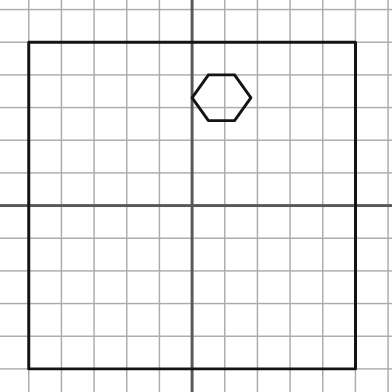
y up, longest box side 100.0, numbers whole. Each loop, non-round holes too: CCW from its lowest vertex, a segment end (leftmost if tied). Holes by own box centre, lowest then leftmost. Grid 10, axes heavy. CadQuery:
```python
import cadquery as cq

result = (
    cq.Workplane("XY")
    .moveTo(-50.0, -50.0)
    .lineTo(50.0, -50.0)
    .lineTo(50.0, 50.0)
    .lineTo(-50.0, 50.0)
    .close()
    .moveTo(5.0, 26.0)
    .lineTo(13.0, 26.0)
    .lineTo(18.0, 33.0)
    .lineTo(13.0, 40.0)
    .lineTo(5.0, 40.0)
    .lineTo(0.0, 33.0)
    .close()
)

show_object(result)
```